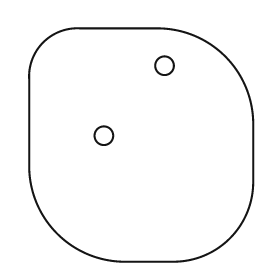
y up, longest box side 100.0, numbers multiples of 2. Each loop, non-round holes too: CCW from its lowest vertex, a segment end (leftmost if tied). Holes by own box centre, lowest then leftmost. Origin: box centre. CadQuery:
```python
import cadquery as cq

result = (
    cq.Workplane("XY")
    .moveTo(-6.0, -50.0)
    .lineTo(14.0, -50.0)
    .threePointArc((38.0, -40.0), (48.0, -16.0))
    .lineTo(48.0, 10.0)
    .threePointArc((36.0, 38.0), (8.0, 50.0))
    .lineTo(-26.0, 50.0)
    .threePointArc((-42.0, 44.0), (-48.0, 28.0))
    .lineTo(-48.0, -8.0)
    .threePointArc((-36.0, -38.0), (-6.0, -50.0))
    .close()
    .moveTo(-16.0, 4.0)
    .circle(4.0)
    .moveTo(10.0, 34.0)
    .circle(4.0)
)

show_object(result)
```